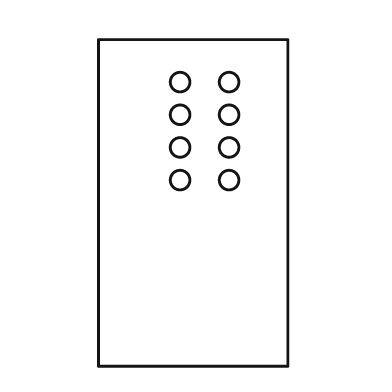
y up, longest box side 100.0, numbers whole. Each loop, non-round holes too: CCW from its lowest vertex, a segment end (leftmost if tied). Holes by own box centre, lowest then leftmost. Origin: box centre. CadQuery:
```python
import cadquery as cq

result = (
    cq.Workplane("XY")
    .moveTo(-29.0, -50.0)
    .lineTo(29.0, -50.0)
    .lineTo(29.0, 50.0)
    .lineTo(-29.0, 50.0)
    .close()
    .moveTo(-4.0, 7.0)
    .circle(3.0)
    .moveTo(11.0, 7.0)
    .circle(3.0)
    .moveTo(-4.0, 17.0)
    .circle(3.0)
    .moveTo(11.0, 17.0)
    .circle(3.0)
    .moveTo(-4.0, 27.0)
    .circle(3.0)
    .moveTo(11.0, 27.0)
    .circle(3.0)
    .moveTo(-4.0, 37.0)
    .circle(3.0)
    .moveTo(11.0, 37.0)
    .circle(3.0)
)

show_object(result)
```